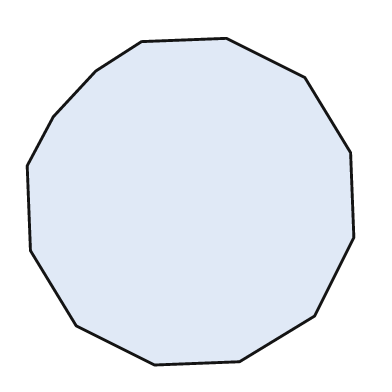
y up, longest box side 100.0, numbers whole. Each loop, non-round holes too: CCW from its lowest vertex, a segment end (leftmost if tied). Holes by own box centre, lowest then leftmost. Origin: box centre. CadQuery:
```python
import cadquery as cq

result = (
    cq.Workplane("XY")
    .moveTo(-11.0, -50.0)
    .lineTo(15.0, -49.0)
    .lineTo(38.0, -35.0)
    .lineTo(50.0, -11.0)
    .lineTo(49.0, 15.0)
    .lineTo(35.0, 38.0)
    .lineTo(11.0, 50.0)
    .lineTo(-15.0, 49.0)
    .lineTo(-29.0, 40.0)
    .lineTo(-42.0, 26.0)
    .lineTo(-50.0, 11.0)
    .lineTo(-49.0, -15.0)
    .lineTo(-35.0, -38.0)
    .close()
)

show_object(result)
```